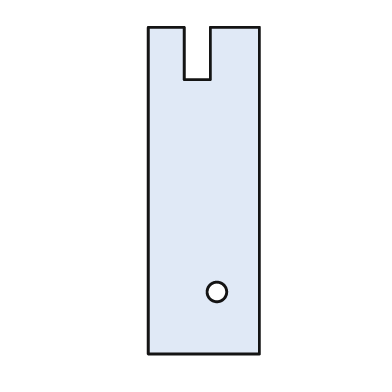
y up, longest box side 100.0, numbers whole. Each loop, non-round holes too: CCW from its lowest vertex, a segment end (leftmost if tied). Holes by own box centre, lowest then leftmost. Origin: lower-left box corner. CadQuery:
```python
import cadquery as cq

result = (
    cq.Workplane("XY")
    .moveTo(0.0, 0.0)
    .lineTo(34.0, 0.0)
    .lineTo(34.0, 100.0)
    .lineTo(19.0, 100.0)
    .lineTo(19.0, 84.0)
    .lineTo(11.0, 84.0)
    .lineTo(11.0, 100.0)
    .lineTo(0.0, 100.0)
    .close()
    .moveTo(21.0, 19.0)
    .circle(3.0)
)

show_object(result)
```